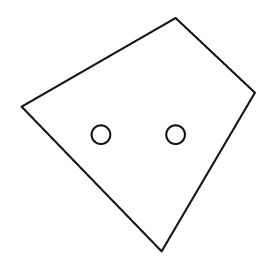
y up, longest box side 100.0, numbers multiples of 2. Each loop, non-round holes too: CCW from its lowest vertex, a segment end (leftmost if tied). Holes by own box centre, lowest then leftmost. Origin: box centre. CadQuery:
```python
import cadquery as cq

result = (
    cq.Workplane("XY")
    .moveTo(10.0, -50.0)
    .lineTo(50.0, 18.0)
    .lineTo(16.0, 50.0)
    .lineTo(-50.0, 12.0)
    .close()
    .moveTo(-16.0, 0.0)
    .circle(4.0)
    .moveTo(16.0, 0.0)
    .circle(4.0)
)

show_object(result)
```